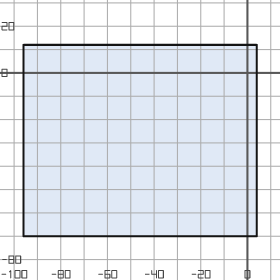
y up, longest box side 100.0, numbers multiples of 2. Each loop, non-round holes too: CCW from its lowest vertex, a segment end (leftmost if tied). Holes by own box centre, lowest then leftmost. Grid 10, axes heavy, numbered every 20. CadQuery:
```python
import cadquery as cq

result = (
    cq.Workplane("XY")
    .moveTo(-96.0, -70.0)
    .lineTo(4.0, -70.0)
    .lineTo(4.0, 12.0)
    .lineTo(-96.0, 12.0)
    .close()
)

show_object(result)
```